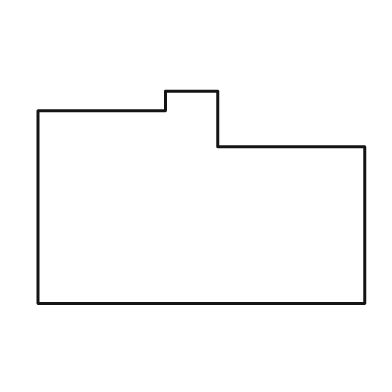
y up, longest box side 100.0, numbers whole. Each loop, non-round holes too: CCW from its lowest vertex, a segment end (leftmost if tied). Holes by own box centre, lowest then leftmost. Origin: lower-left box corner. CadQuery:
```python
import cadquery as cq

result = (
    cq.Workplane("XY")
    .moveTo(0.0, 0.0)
    .lineTo(100.0, 0.0)
    .lineTo(100.0, 48.0)
    .lineTo(55.0, 48.0)
    .lineTo(55.0, 65.0)
    .lineTo(39.0, 65.0)
    .lineTo(39.0, 59.0)
    .lineTo(0.0, 59.0)
    .close()
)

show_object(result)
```